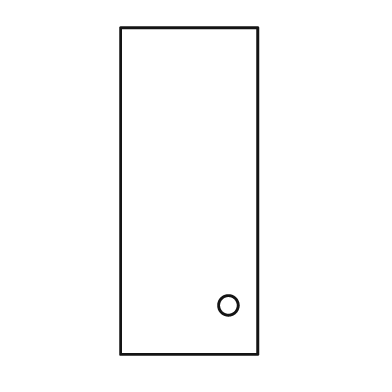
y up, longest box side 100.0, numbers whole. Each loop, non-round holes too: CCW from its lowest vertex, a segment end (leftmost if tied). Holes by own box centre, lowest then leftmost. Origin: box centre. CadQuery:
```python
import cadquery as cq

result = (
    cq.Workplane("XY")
    .moveTo(-21.0, -50.0)
    .lineTo(21.0, -50.0)
    .lineTo(21.0, 50.0)
    .lineTo(-21.0, 50.0)
    .close()
    .moveTo(12.0, -35.0)
    .circle(3.0)
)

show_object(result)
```